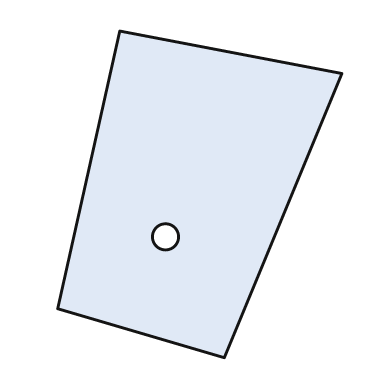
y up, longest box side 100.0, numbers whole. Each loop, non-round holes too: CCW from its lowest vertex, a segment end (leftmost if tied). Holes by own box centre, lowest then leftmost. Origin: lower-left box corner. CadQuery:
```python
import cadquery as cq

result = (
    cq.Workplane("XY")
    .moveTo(51.0, 0.0)
    .lineTo(87.0, 87.0)
    .lineTo(19.0, 100.0)
    .lineTo(0.0, 15.0)
    .close()
    .moveTo(33.0, 37.0)
    .circle(4.0)
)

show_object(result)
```